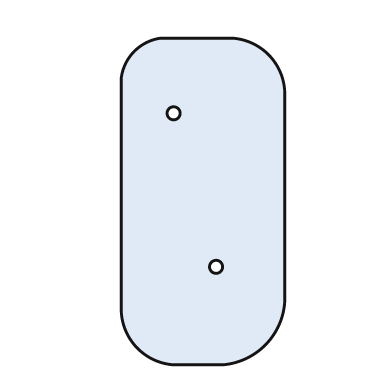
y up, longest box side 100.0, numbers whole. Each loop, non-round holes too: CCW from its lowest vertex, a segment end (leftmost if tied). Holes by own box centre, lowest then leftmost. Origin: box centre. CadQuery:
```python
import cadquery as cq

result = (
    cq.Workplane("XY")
    .moveTo(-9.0, -50.0)
    .lineTo(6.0, -50.0)
    .threePointArc((19.0, -44.0), (25.0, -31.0))
    .lineTo(25.0, 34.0)
    .threePointArc((20.0, 45.0), (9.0, 50.0))
    .lineTo(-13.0, 50.0)
    .threePointArc((-21.0, 46.0), (-25.0, 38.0))
    .lineTo(-25.0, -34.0)
    .threePointArc((-20.0, -45.0), (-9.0, -50.0))
    .close()
    .moveTo(4.0, -20.0)
    .circle(2.0)
    .moveTo(-9.0, 27.0)
    .circle(2.0)
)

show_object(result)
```